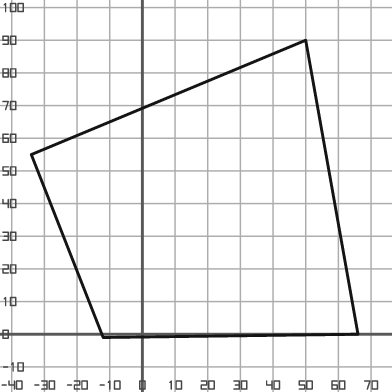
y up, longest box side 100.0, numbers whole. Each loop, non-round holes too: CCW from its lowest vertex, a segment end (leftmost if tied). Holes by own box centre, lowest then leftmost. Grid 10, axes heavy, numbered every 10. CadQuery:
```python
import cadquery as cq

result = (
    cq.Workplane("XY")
    .moveTo(-12.0, -1.0)
    .lineTo(66.0, 0.0)
    .lineTo(50.0, 90.0)
    .lineTo(-34.0, 55.0)
    .close()
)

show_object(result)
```